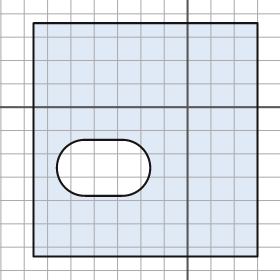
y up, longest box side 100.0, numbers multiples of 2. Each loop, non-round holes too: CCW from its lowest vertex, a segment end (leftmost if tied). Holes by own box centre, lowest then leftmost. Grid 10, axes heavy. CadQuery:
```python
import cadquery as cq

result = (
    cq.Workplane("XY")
    .moveTo(-66.0, -64.0)
    .lineTo(30.0, -64.0)
    .lineTo(30.0, 36.0)
    .lineTo(-66.0, 36.0)
    .close()
    .moveTo(-44.0, -38.0)
    .lineTo(-28.0, -38.0)
    .threePointArc((-16.0, -26.0), (-28.0, -14.0))
    .lineTo(-44.0, -14.0)
    .threePointArc((-56.0, -26.0), (-44.0, -38.0))
    .close()
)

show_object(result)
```